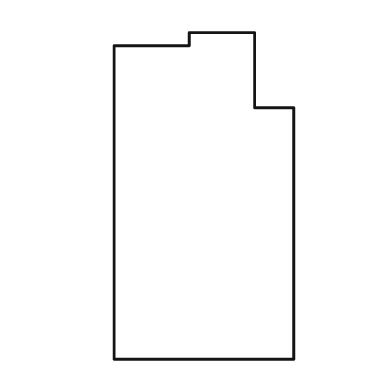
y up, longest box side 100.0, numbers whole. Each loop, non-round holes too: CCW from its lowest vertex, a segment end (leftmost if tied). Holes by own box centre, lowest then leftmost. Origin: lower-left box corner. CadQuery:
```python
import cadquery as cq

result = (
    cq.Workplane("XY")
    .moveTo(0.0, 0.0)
    .lineTo(55.0, 0.0)
    .lineTo(55.0, 77.0)
    .lineTo(43.0, 77.0)
    .lineTo(43.0, 100.0)
    .lineTo(23.0, 100.0)
    .lineTo(23.0, 96.0)
    .lineTo(0.0, 96.0)
    .close()
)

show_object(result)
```